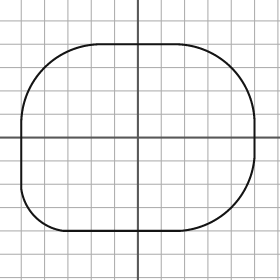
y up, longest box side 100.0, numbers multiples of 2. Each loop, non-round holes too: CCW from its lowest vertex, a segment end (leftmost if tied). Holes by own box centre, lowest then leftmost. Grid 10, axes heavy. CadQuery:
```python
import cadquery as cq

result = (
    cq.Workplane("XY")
    .moveTo(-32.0, -40.0)
    .lineTo(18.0, -40.0)
    .threePointArc((40.0, -30.0), (50.0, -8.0))
    .lineTo(50.0, 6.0)
    .threePointArc((40.0, 30.0), (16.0, 40.0))
    .lineTo(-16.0, 40.0)
    .threePointArc((-40.0, 30.0), (-50.0, 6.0))
    .lineTo(-50.0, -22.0)
    .threePointArc((-44.0, -34.0), (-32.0, -40.0))
    .close()
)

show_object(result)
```